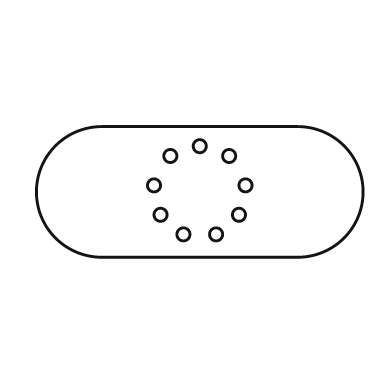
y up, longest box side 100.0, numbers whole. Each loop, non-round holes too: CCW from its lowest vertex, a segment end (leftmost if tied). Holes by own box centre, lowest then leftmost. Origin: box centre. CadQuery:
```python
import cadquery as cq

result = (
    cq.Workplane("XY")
    .moveTo(-30.0, -20.0)
    .lineTo(30.0, -20.0)
    .threePointArc((50.0, 0.0), (30.0, 20.0))
    .lineTo(-30.0, 20.0)
    .threePointArc((-50.0, 0.0), (-30.0, -20.0))
    .close()
    .moveTo(-5.0, -13.0)
    .circle(2.0)
    .moveTo(5.0, -13.0)
    .circle(2.0)
    .moveTo(-12.0, -7.0)
    .circle(2.0)
    .moveTo(12.0, -7.0)
    .circle(2.0)
    .moveTo(-14.0, 2.0)
    .circle(2.0)
    .moveTo(14.0, 2.0)
    .circle(2.0)
    .moveTo(-9.0, 11.0)
    .circle(2.0)
    .moveTo(9.0, 11.0)
    .circle(2.0)
    .moveTo(0.0, 14.0)
    .circle(2.0)
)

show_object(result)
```